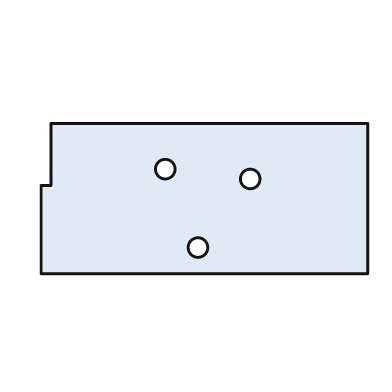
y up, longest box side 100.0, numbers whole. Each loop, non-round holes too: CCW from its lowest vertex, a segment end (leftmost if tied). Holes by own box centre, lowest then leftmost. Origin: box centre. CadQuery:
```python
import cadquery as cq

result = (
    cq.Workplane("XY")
    .moveTo(-50.0, -23.0)
    .lineTo(50.0, -23.0)
    .lineTo(50.0, 23.0)
    .lineTo(-47.0, 23.0)
    .lineTo(-47.0, 4.0)
    .lineTo(-50.0, 4.0)
    .close()
    .moveTo(-2.0, -15.0)
    .circle(3.0)
    .moveTo(14.0, 6.0)
    .circle(3.0)
    .moveTo(-12.0, 9.0)
    .circle(3.0)
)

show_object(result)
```